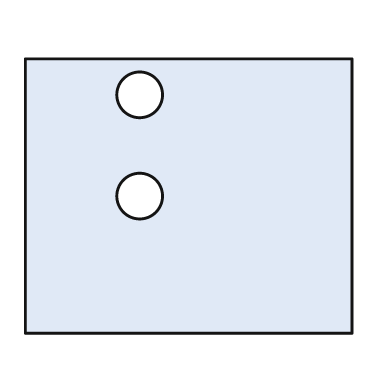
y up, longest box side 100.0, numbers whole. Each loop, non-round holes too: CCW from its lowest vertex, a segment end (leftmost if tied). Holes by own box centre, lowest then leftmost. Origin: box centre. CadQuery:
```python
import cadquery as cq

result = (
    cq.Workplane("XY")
    .moveTo(-50.0, -42.0)
    .lineTo(50.0, -42.0)
    .lineTo(50.0, 42.0)
    .lineTo(-50.0, 42.0)
    .close()
    .moveTo(-15.0, 0.0)
    .circle(7.0)
    .moveTo(-15.0, 31.0)
    .circle(7.0)
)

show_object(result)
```